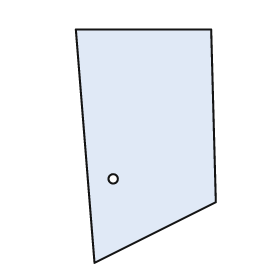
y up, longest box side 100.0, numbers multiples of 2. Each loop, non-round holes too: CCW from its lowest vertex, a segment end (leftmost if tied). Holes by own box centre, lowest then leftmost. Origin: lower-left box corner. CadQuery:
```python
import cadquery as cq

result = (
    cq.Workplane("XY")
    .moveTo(8.0, 0.0)
    .lineTo(60.0, 26.0)
    .lineTo(58.0, 100.0)
    .lineTo(0.0, 100.0)
    .close()
    .moveTo(16.0, 36.0)
    .circle(2.0)
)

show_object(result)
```